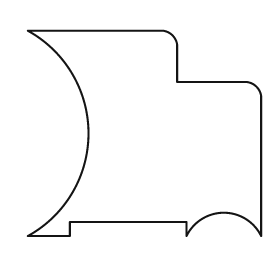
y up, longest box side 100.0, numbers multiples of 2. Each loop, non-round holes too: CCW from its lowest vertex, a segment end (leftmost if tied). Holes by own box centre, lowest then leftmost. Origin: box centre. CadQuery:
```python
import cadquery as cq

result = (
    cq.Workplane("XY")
    .moveTo(-50.0, -44.0)
    .lineTo(-32.0, -44.0)
    .lineTo(-32.0, -38.0)
    .lineTo(18.0, -38.0)
    .lineTo(18.0, -44.0)
    .threePointArc((34.0, -34.0), (50.0, -44.0))
    .lineTo(50.0, 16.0)
    .threePointArc((48.0, 20.0), (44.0, 22.0))
    .lineTo(14.0, 22.0)
    .lineTo(14.0, 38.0)
    .threePointArc((12.0, 42.0), (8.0, 44.0))
    .lineTo(-50.0, 44.0)
    .threePointArc((-24.0, 0.0), (-50.0, -44.0))
    .close()
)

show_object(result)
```